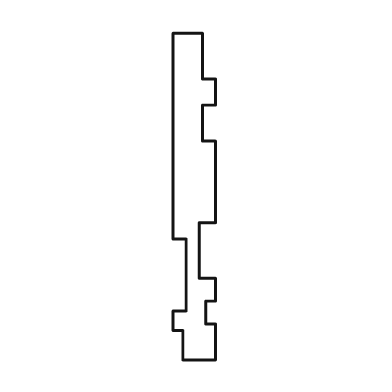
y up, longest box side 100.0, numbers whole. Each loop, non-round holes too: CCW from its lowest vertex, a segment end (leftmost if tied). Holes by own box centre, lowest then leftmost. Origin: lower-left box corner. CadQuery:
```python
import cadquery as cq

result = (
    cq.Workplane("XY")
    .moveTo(3.0, 0.0)
    .lineTo(13.0, 0.0)
    .lineTo(13.0, 11.0)
    .lineTo(10.0, 11.0)
    .lineTo(10.0, 18.0)
    .lineTo(13.0, 18.0)
    .lineTo(13.0, 25.0)
    .lineTo(8.0, 25.0)
    .lineTo(8.0, 42.0)
    .lineTo(13.0, 42.0)
    .lineTo(13.0, 67.0)
    .lineTo(9.0, 67.0)
    .lineTo(9.0, 78.0)
    .lineTo(13.0, 78.0)
    .lineTo(13.0, 86.0)
    .lineTo(9.0, 86.0)
    .lineTo(9.0, 100.0)
    .lineTo(0.0, 100.0)
    .lineTo(0.0, 37.0)
    .lineTo(4.0, 37.0)
    .lineTo(4.0, 15.0)
    .lineTo(0.0, 15.0)
    .lineTo(0.0, 9.0)
    .lineTo(3.0, 9.0)
    .close()
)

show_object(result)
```